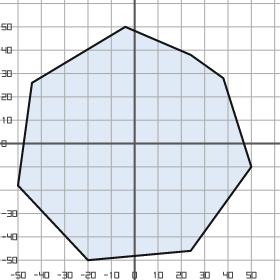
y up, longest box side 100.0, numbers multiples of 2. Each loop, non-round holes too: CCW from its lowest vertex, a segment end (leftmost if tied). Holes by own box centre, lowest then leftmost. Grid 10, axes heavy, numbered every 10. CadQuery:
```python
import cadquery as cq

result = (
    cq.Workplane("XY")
    .moveTo(-20.0, -50.0)
    .lineTo(24.0, -46.0)
    .lineTo(50.0, -10.0)
    .lineTo(38.0, 28.0)
    .lineTo(24.0, 38.0)
    .lineTo(-4.0, 50.0)
    .lineTo(-44.0, 26.0)
    .lineTo(-50.0, -18.0)
    .close()
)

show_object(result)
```